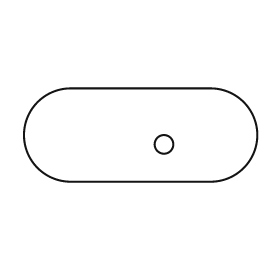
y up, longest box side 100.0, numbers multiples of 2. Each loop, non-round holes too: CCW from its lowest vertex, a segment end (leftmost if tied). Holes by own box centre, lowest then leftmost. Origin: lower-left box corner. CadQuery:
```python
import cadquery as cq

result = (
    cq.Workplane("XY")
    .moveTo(20.0, 0.0)
    .lineTo(80.0, 0.0)
    .threePointArc((100.0, 20.0), (80.0, 40.0))
    .lineTo(20.0, 40.0)
    .threePointArc((0.0, 20.0), (20.0, 0.0))
    .close()
    .moveTo(60.0, 16.0)
    .circle(4.0)
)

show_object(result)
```